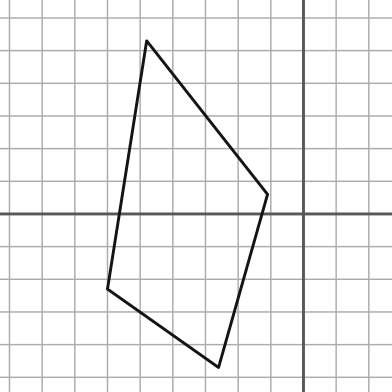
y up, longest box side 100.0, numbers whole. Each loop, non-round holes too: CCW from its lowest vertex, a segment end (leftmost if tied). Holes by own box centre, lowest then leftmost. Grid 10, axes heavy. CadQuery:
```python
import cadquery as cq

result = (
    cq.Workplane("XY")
    .moveTo(-26.0, -47.0)
    .lineTo(-11.0, 6.0)
    .lineTo(-48.0, 53.0)
    .lineTo(-60.0, -23.0)
    .close()
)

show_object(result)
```